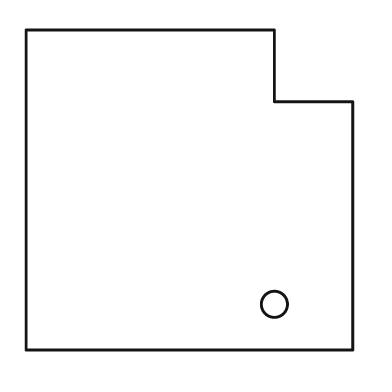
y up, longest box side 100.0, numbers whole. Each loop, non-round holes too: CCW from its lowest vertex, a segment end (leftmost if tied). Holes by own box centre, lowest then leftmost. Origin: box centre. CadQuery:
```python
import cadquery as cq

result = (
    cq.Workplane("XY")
    .moveTo(-50.0, -49.0)
    .lineTo(50.0, -49.0)
    .lineTo(50.0, 27.0)
    .lineTo(26.0, 27.0)
    .lineTo(26.0, 49.0)
    .lineTo(-50.0, 49.0)
    .close()
    .moveTo(26.0, -35.0)
    .circle(4.0)
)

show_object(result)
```